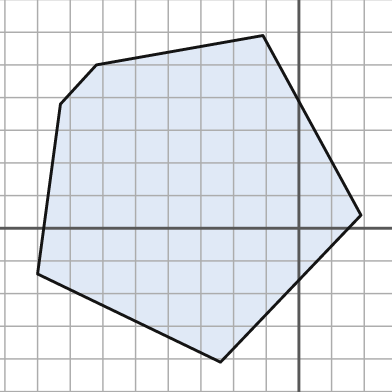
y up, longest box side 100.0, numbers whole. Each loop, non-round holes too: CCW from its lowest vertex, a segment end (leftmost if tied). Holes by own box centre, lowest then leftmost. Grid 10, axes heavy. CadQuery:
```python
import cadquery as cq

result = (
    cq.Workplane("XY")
    .moveTo(-24.0, -41.0)
    .lineTo(19.0, 4.0)
    .lineTo(-11.0, 59.0)
    .lineTo(-62.0, 50.0)
    .lineTo(-73.0, 38.0)
    .lineTo(-80.0, -14.0)
    .close()
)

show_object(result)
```